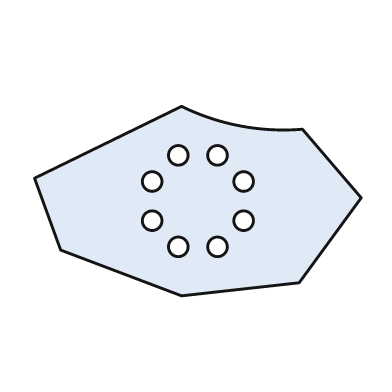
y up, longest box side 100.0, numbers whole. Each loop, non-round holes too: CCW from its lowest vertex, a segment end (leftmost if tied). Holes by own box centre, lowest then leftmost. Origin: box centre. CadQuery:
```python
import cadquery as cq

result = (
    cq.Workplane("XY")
    .moveTo(-5.0, -29.0)
    .lineTo(31.0, -25.0)
    .lineTo(50.0, 1.0)
    .lineTo(32.0, 22.0)
    .threePointArc((13.0, 23.0), (-5.0, 29.0))
    .lineTo(-50.0, 7.0)
    .lineTo(-42.0, -15.0)
    .close()
    .moveTo(-6.0, -14.0)
    .circle(3.0)
    .moveTo(6.0, -14.0)
    .circle(3.0)
    .moveTo(-14.0, -6.0)
    .circle(3.0)
    .moveTo(14.0, -6.0)
    .circle(3.0)
    .moveTo(-14.0, 6.0)
    .circle(3.0)
    .moveTo(14.0, 6.0)
    .circle(3.0)
    .moveTo(-6.0, 14.0)
    .circle(3.0)
    .moveTo(6.0, 14.0)
    .circle(3.0)
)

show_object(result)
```